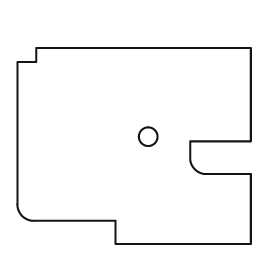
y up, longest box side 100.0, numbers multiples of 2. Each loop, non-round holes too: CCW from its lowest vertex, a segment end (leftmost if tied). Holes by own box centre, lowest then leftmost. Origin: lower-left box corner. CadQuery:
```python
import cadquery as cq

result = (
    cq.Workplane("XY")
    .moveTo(42.0, 0.0)
    .lineTo(100.0, 0.0)
    .lineTo(100.0, 30.0)
    .lineTo(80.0, 30.0)
    .threePointArc((76.0, 32.0), (74.0, 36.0))
    .lineTo(74.0, 44.0)
    .lineTo(100.0, 44.0)
    .lineTo(100.0, 84.0)
    .lineTo(8.0, 84.0)
    .lineTo(8.0, 78.0)
    .lineTo(0.0, 78.0)
    .lineTo(0.0, 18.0)
    .threePointArc((2.0, 12.0), (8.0, 10.0))
    .lineTo(42.0, 10.0)
    .close()
    .moveTo(56.0, 46.0)
    .circle(4.0)
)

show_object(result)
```